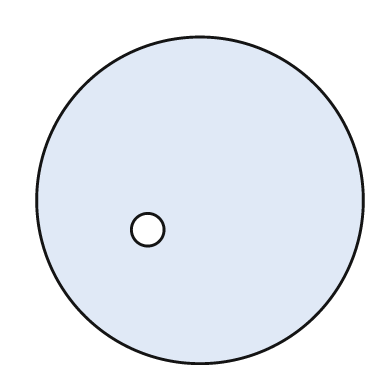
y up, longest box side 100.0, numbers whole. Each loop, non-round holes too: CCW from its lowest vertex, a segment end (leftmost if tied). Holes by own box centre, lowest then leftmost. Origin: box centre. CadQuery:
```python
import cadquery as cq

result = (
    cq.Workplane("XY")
    .moveTo(0.0, 0.0)
    .circle(50.0)
    .moveTo(-16.0, -9.0)
    .circle(5.0)
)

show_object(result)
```